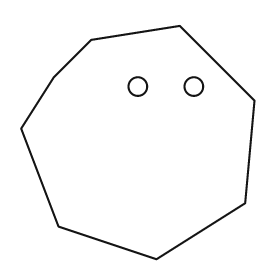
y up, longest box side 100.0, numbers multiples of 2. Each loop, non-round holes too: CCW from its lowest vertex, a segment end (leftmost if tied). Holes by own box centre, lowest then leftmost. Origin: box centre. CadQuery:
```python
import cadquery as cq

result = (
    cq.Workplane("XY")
    .moveTo(8.0, -50.0)
    .lineTo(46.0, -26.0)
    .lineTo(50.0, 18.0)
    .lineTo(18.0, 50.0)
    .lineTo(-20.0, 44.0)
    .lineTo(-36.0, 28.0)
    .lineTo(-50.0, 6.0)
    .lineTo(-34.0, -36.0)
    .close()
    .moveTo(0.0, 24.0)
    .circle(4.0)
    .moveTo(24.0, 24.0)
    .circle(4.0)
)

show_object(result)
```